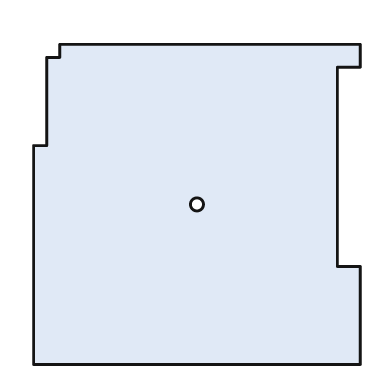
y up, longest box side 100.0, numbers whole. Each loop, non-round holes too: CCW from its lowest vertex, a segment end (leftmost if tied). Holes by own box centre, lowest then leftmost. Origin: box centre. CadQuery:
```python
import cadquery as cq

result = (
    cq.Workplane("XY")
    .moveTo(-50.0, -49.0)
    .lineTo(50.0, -49.0)
    .lineTo(50.0, -19.0)
    .lineTo(43.0, -19.0)
    .lineTo(43.0, 42.0)
    .lineTo(50.0, 42.0)
    .lineTo(50.0, 49.0)
    .lineTo(-42.0, 49.0)
    .lineTo(-42.0, 45.0)
    .lineTo(-46.0, 45.0)
    .lineTo(-46.0, 18.0)
    .lineTo(-50.0, 18.0)
    .close()
    .moveTo(0.0, 0.0)
    .circle(2.0)
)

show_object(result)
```